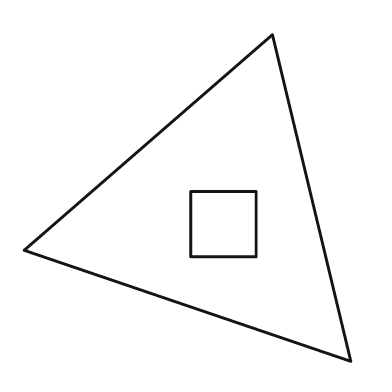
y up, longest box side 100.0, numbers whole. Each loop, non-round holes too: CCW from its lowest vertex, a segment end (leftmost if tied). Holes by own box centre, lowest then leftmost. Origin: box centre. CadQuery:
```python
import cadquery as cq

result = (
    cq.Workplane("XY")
    .moveTo(50.0, -50.0)
    .lineTo(26.0, 50.0)
    .lineTo(-50.0, -16.0)
    .close()
    .moveTo(1.0, -18.0)
    .lineTo(21.0, -18.0)
    .lineTo(21.0, 2.0)
    .lineTo(1.0, 2.0)
    .close()
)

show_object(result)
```